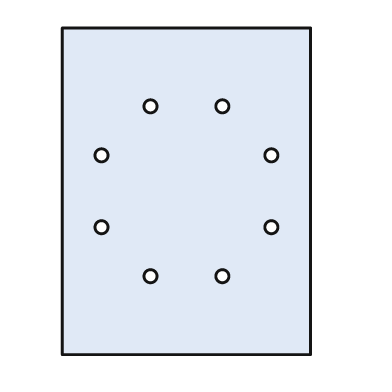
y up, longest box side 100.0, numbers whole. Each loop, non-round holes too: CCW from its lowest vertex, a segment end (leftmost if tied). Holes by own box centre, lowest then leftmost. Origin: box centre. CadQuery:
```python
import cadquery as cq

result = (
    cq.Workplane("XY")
    .moveTo(-38.0, -50.0)
    .lineTo(38.0, -50.0)
    .lineTo(38.0, 50.0)
    .lineTo(-38.0, 50.0)
    .close()
    .moveTo(-11.0, -26.0)
    .circle(2.0)
    .moveTo(11.0, -26.0)
    .circle(2.0)
    .moveTo(-26.0, -11.0)
    .circle(2.0)
    .moveTo(26.0, -11.0)
    .circle(2.0)
    .moveTo(-26.0, 11.0)
    .circle(2.0)
    .moveTo(26.0, 11.0)
    .circle(2.0)
    .moveTo(-11.0, 26.0)
    .circle(2.0)
    .moveTo(11.0, 26.0)
    .circle(2.0)
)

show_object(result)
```